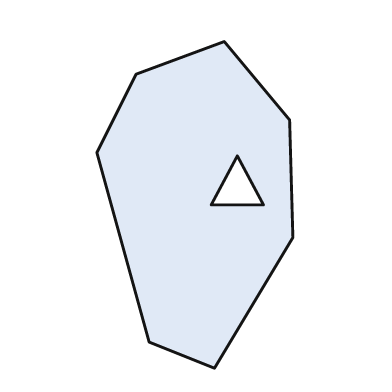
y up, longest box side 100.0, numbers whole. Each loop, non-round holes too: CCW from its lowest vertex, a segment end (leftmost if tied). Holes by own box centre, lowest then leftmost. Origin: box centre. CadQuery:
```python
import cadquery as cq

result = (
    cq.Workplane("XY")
    .moveTo(6.0, -50.0)
    .lineTo(30.0, -10.0)
    .lineTo(29.0, 26.0)
    .lineTo(9.0, 50.0)
    .lineTo(-18.0, 40.0)
    .lineTo(-30.0, 16.0)
    .lineTo(-14.0, -42.0)
    .close()
    .moveTo(5.0, 0.0)
    .lineTo(21.0, 0.0)
    .lineTo(13.0, 15.0)
    .close()
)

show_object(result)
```